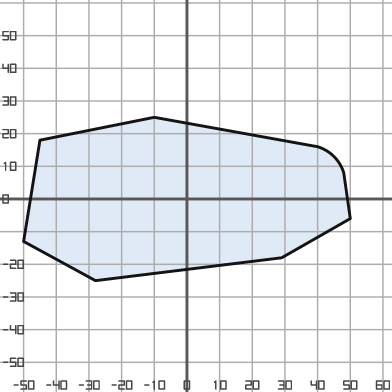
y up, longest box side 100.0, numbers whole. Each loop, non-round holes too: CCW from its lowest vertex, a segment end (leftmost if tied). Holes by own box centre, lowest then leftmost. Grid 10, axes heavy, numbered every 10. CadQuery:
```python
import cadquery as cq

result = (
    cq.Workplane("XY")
    .moveTo(-28.0, -25.0)
    .lineTo(29.0, -18.0)
    .lineTo(50.0, -6.0)
    .lineTo(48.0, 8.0)
    .threePointArc((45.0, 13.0), (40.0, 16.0))
    .lineTo(-10.0, 25.0)
    .lineTo(-45.0, 18.0)
    .lineTo(-50.0, -13.0)
    .close()
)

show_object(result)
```